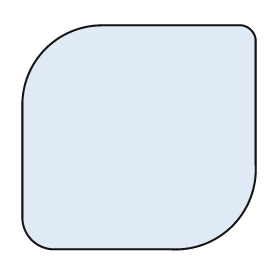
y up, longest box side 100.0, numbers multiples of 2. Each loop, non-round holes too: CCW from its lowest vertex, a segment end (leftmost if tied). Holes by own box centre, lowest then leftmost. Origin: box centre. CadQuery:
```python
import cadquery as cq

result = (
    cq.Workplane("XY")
    .moveTo(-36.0, -48.0)
    .lineTo(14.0, -48.0)
    .threePointArc((40.0, -38.0), (50.0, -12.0))
    .lineTo(50.0, 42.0)
    .threePointArc((48.0, 46.0), (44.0, 48.0))
    .lineTo(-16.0, 48.0)
    .threePointArc((-40.0, 38.0), (-50.0, 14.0))
    .lineTo(-50.0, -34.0)
    .threePointArc((-46.0, -44.0), (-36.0, -48.0))
    .close()
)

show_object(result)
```